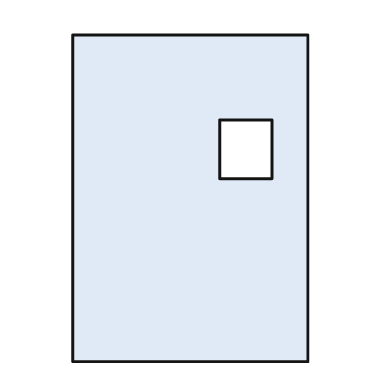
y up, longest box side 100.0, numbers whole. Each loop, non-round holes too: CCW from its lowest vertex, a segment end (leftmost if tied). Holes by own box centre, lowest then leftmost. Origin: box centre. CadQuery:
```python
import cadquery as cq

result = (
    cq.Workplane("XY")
    .moveTo(-36.0, -50.0)
    .lineTo(36.0, -50.0)
    .lineTo(36.0, 50.0)
    .lineTo(-36.0, 50.0)
    .close()
    .moveTo(9.0, 6.0)
    .lineTo(25.0, 6.0)
    .lineTo(25.0, 24.0)
    .lineTo(9.0, 24.0)
    .close()
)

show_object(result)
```